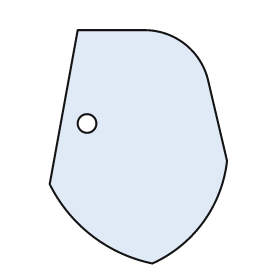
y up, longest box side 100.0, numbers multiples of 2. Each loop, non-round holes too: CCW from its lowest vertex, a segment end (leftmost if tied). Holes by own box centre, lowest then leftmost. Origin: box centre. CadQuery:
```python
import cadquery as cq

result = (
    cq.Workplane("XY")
    .moveTo(6.0, -50.0)
    .threePointArc((28.0, -32.0), (38.0, -6.0))
    .lineTo(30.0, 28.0)
    .threePointArc((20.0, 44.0), (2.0, 50.0))
    .lineTo(-26.0, 50.0)
    .lineTo(-38.0, -16.0)
    .threePointArc((-20.0, -38.0), (6.0, -50.0))
    .close()
    .moveTo(-22.0, 10.0)
    .circle(4.0)
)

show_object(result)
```